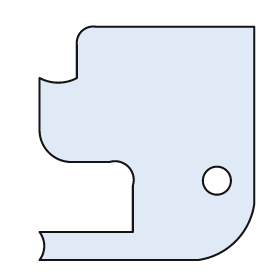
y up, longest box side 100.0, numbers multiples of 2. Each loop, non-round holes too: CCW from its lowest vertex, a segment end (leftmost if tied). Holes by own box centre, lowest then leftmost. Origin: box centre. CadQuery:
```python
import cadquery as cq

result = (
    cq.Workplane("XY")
    .moveTo(-46.0, -50.0)
    .lineTo(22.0, -50.0)
    .threePointArc((38.0, -42.0), (46.0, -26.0))
    .lineTo(46.0, 50.0)
    .lineTo(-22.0, 50.0)
    .threePointArc((-28.0, 48.0), (-30.0, 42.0))
    .lineTo(-30.0, 28.0)
    .threePointArc((-38.0, 26.0), (-46.0, 28.0))
    .lineTo(-46.0, 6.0)
    .threePointArc((-42.0, -4.0), (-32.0, -8.0))
    .lineTo(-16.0, -8.0)
    .threePointArc((-8.0, -10.0), (-6.0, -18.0))
    .lineTo(-6.0, -38.0)
    .lineTo(-46.0, -38.0)
    .threePointArc((-44.0, -44.0), (-46.0, -50.0))
    .close()
    .moveTo(30.0, -16.0)
    .circle(6.0)
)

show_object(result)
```